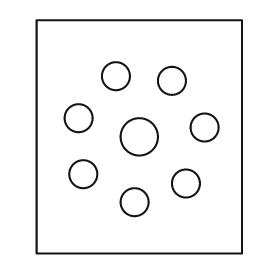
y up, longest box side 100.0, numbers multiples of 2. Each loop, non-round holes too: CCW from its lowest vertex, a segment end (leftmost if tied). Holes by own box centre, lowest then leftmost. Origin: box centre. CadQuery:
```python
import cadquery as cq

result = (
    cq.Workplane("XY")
    .moveTo(-44.0, -50.0)
    .lineTo(44.0, -50.0)
    .lineTo(44.0, 50.0)
    .lineTo(-44.0, 50.0)
    .close()
    .moveTo(-2.0, -28.0)
    .circle(6.0)
    .moveTo(20.0, -20.0)
    .circle(6.0)
    .moveTo(-24.0, -16.0)
    .circle(6.0)
    .moveTo(0.0, 0.0)
    .circle(8.0)
    .moveTo(28.0, 4.0)
    .circle(6.0)
    .moveTo(-26.0, 8.0)
    .circle(6.0)
    .moveTo(14.0, 24.0)
    .circle(6.0)
    .moveTo(-10.0, 26.0)
    .circle(6.0)
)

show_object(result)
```